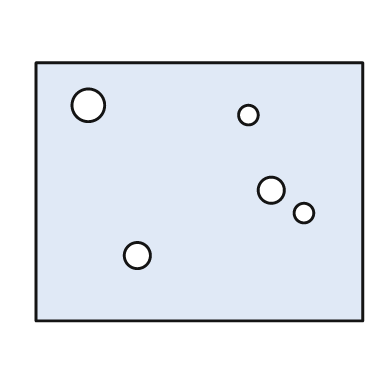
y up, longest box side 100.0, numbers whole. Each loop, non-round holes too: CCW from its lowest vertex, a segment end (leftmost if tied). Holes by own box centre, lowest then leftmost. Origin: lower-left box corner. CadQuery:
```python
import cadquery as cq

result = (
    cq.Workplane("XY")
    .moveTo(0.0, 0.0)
    .lineTo(100.0, 0.0)
    .lineTo(100.0, 79.0)
    .lineTo(0.0, 79.0)
    .close()
    .moveTo(31.0, 20.0)
    .circle(4.0)
    .moveTo(82.0, 33.0)
    .circle(3.0)
    .moveTo(72.0, 40.0)
    .circle(4.0)
    .moveTo(65.0, 63.0)
    .circle(3.0)
    .moveTo(16.0, 66.0)
    .circle(5.0)
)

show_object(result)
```